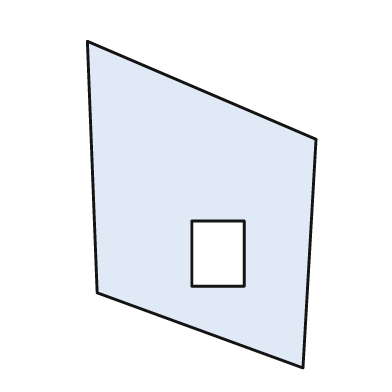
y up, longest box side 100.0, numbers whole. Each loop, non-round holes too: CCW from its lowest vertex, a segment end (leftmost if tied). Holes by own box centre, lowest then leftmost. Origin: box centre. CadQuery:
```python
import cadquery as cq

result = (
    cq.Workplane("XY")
    .moveTo(31.0, -50.0)
    .lineTo(35.0, 20.0)
    .lineTo(-35.0, 50.0)
    .lineTo(-32.0, -27.0)
    .close()
    .moveTo(-3.0, -25.0)
    .lineTo(13.0, -25.0)
    .lineTo(13.0, -5.0)
    .lineTo(-3.0, -5.0)
    .close()
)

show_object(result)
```